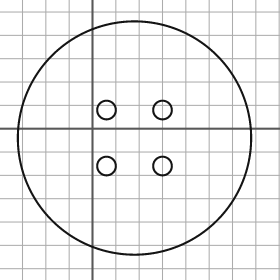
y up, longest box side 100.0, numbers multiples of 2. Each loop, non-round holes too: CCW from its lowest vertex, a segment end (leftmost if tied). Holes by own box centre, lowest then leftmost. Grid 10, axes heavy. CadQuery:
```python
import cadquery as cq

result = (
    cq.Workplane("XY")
    .moveTo(18.0, -4.0)
    .circle(50.0)
    .moveTo(6.0, -16.0)
    .circle(4.0)
    .moveTo(30.0, -16.0)
    .circle(4.0)
    .moveTo(6.0, 8.0)
    .circle(4.0)
    .moveTo(30.0, 8.0)
    .circle(4.0)
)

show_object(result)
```